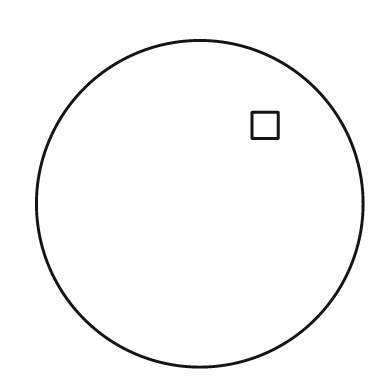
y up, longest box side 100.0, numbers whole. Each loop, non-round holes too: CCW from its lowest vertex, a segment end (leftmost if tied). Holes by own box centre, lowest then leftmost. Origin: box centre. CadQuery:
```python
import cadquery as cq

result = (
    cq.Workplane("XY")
    .moveTo(0.0, 0.0)
    .circle(50.0)
    .moveTo(16.0, 20.0)
    .lineTo(24.0, 20.0)
    .lineTo(24.0, 28.0)
    .lineTo(16.0, 28.0)
    .close()
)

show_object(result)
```